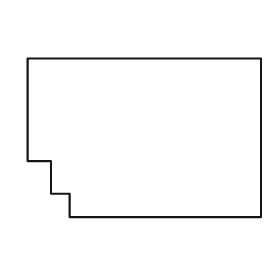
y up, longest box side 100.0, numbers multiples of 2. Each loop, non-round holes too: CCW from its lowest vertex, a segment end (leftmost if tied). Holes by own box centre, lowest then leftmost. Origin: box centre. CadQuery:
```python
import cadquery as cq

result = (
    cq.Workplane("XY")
    .moveTo(-32.0, -34.0)
    .lineTo(50.0, -34.0)
    .lineTo(50.0, 34.0)
    .lineTo(-50.0, 34.0)
    .lineTo(-50.0, -10.0)
    .lineTo(-40.0, -10.0)
    .lineTo(-40.0, -24.0)
    .lineTo(-32.0, -24.0)
    .close()
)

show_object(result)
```